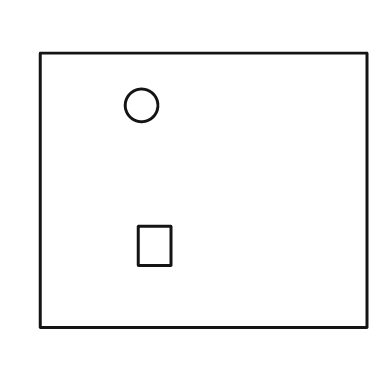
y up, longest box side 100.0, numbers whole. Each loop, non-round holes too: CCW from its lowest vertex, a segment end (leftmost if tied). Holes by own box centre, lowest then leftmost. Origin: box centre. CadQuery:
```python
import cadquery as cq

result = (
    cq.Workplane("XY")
    .moveTo(-50.0, -42.0)
    .lineTo(50.0, -42.0)
    .lineTo(50.0, 42.0)
    .lineTo(-50.0, 42.0)
    .close()
    .moveTo(-20.0, -23.0)
    .lineTo(-10.0, -23.0)
    .lineTo(-10.0, -11.0)
    .lineTo(-20.0, -11.0)
    .close()
    .moveTo(-19.0, 26.0)
    .circle(5.0)
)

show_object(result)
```